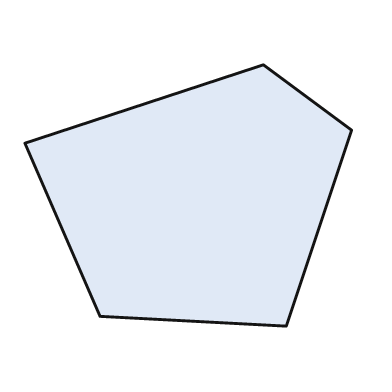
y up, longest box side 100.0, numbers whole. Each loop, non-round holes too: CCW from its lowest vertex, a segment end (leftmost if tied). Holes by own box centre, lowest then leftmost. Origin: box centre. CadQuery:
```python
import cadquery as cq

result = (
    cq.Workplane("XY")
    .moveTo(30.0, -40.0)
    .lineTo(50.0, 20.0)
    .lineTo(23.0, 40.0)
    .lineTo(-50.0, 16.0)
    .lineTo(-27.0, -37.0)
    .close()
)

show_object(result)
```